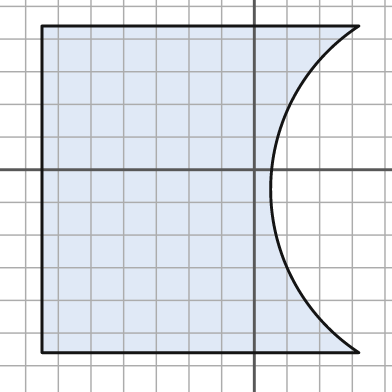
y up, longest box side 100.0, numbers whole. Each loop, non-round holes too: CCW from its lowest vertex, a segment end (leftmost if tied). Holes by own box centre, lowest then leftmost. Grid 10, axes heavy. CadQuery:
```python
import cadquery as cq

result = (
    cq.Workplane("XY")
    .moveTo(-65.0, -56.0)
    .lineTo(32.0, -56.0)
    .threePointArc((5.0, -6.0), (32.0, 44.0))
    .lineTo(-65.0, 44.0)
    .close()
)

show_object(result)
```